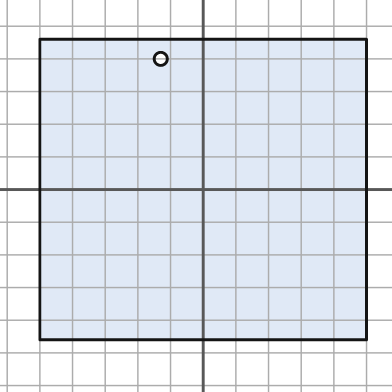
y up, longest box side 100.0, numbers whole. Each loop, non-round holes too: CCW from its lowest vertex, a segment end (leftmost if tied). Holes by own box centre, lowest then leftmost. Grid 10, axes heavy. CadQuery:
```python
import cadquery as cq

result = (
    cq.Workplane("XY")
    .moveTo(-50.0, -46.0)
    .lineTo(50.0, -46.0)
    .lineTo(50.0, 46.0)
    .lineTo(-50.0, 46.0)
    .close()
    .moveTo(-13.0, 40.0)
    .circle(2.0)
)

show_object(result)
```